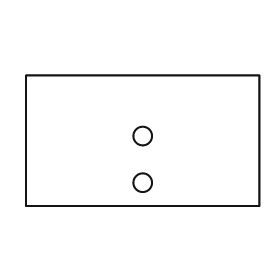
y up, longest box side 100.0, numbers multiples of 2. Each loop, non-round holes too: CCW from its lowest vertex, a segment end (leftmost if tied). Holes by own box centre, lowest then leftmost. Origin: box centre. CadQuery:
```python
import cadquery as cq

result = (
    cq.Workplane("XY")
    .moveTo(-50.0, -28.0)
    .lineTo(50.0, -28.0)
    .lineTo(50.0, 28.0)
    .lineTo(-50.0, 28.0)
    .close()
    .moveTo(0.0, -18.0)
    .circle(4.0)
    .moveTo(0.0, 2.0)
    .circle(4.0)
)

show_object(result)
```